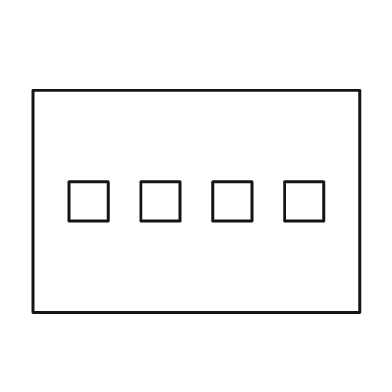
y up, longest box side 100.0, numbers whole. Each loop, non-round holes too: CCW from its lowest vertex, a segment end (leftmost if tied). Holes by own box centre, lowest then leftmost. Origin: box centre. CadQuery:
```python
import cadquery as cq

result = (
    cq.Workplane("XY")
    .moveTo(-50.0, -34.0)
    .lineTo(50.0, -34.0)
    .lineTo(50.0, 34.0)
    .lineTo(-50.0, 34.0)
    .close()
    .moveTo(-39.0, -6.0)
    .lineTo(-27.0, -6.0)
    .lineTo(-27.0, 6.0)
    .lineTo(-39.0, 6.0)
    .close()
    .moveTo(-17.0, -6.0)
    .lineTo(-5.0, -6.0)
    .lineTo(-5.0, 6.0)
    .lineTo(-17.0, 6.0)
    .close()
    .moveTo(5.0, -6.0)
    .lineTo(17.0, -6.0)
    .lineTo(17.0, 6.0)
    .lineTo(5.0, 6.0)
    .close()
    .moveTo(27.0, -6.0)
    .lineTo(39.0, -6.0)
    .lineTo(39.0, 6.0)
    .lineTo(27.0, 6.0)
    .close()
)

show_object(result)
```